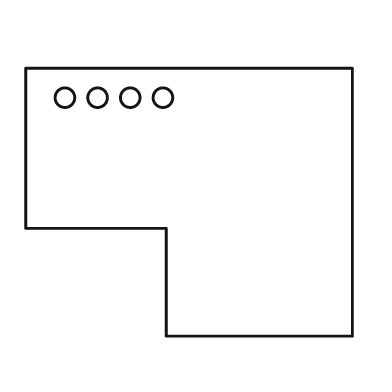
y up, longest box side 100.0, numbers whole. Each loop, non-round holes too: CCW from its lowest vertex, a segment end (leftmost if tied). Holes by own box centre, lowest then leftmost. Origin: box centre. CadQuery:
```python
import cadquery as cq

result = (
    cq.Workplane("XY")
    .moveTo(-7.0, -41.0)
    .lineTo(50.0, -41.0)
    .lineTo(50.0, 41.0)
    .lineTo(-50.0, 41.0)
    .lineTo(-50.0, -8.0)
    .lineTo(-7.0, -8.0)
    .close()
    .moveTo(-38.0, 32.0)
    .circle(3.0)
    .moveTo(-28.0, 32.0)
    .circle(3.0)
    .moveTo(-18.0, 32.0)
    .circle(3.0)
    .moveTo(-8.0, 32.0)
    .circle(3.0)
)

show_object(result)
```